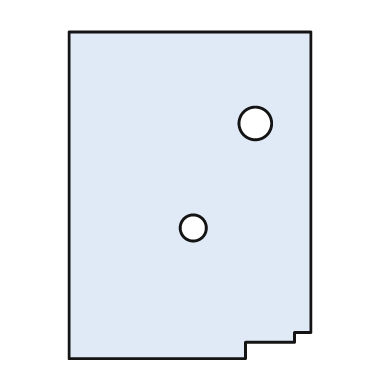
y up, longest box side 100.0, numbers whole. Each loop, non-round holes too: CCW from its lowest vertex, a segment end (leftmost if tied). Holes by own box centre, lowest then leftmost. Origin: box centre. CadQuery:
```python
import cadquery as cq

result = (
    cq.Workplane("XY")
    .moveTo(-37.0, -50.0)
    .lineTo(17.0, -50.0)
    .lineTo(17.0, -45.0)
    .lineTo(32.0, -45.0)
    .lineTo(32.0, -42.0)
    .lineTo(37.0, -42.0)
    .lineTo(37.0, 50.0)
    .lineTo(-37.0, 50.0)
    .close()
    .moveTo(1.0, -10.0)
    .circle(4.0)
    .moveTo(20.0, 22.0)
    .circle(5.0)
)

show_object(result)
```